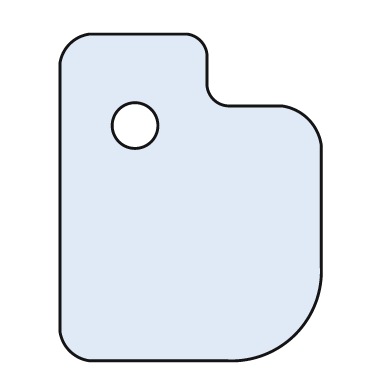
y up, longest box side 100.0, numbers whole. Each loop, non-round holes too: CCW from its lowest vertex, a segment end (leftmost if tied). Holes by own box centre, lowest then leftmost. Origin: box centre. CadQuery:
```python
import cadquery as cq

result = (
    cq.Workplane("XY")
    .moveTo(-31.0, -50.0)
    .lineTo(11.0, -50.0)
    .threePointArc((32.0, -42.0), (40.0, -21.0))
    .lineTo(40.0, 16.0)
    .threePointArc((36.0, 24.0), (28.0, 28.0))
    .lineTo(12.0, 28.0)
    .threePointArc((7.0, 30.0), (5.0, 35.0))
    .lineTo(5.0, 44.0)
    .threePointArc((3.0, 48.0), (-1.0, 50.0))
    .lineTo(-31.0, 50.0)
    .threePointArc((-37.0, 47.0), (-40.0, 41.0))
    .lineTo(-40.0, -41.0)
    .threePointArc((-37.0, -47.0), (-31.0, -50.0))
    .close()
    .moveTo(-17.0, 22.0)
    .circle(7.0)
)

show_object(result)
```